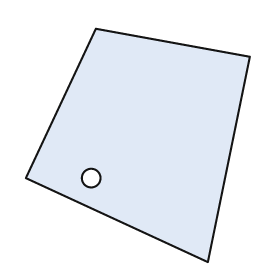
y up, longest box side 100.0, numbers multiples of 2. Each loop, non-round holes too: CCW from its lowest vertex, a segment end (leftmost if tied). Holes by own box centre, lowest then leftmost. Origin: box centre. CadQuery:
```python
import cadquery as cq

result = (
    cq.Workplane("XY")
    .moveTo(30.0, -50.0)
    .lineTo(48.0, 38.0)
    .lineTo(-18.0, 50.0)
    .lineTo(-48.0, -14.0)
    .close()
    .moveTo(-20.0, -14.0)
    .circle(4.0)
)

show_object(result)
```